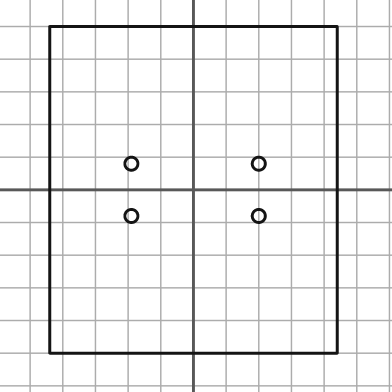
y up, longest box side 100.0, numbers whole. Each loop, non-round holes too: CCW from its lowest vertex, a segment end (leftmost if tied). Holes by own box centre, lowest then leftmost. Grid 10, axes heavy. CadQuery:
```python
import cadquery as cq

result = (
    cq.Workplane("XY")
    .moveTo(-44.0, -50.0)
    .lineTo(44.0, -50.0)
    .lineTo(44.0, 50.0)
    .lineTo(-44.0, 50.0)
    .close()
    .moveTo(-19.0, -8.0)
    .circle(2.0)
    .moveTo(20.0, -8.0)
    .circle(2.0)
    .moveTo(-19.0, 8.0)
    .circle(2.0)
    .moveTo(20.0, 8.0)
    .circle(2.0)
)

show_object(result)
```